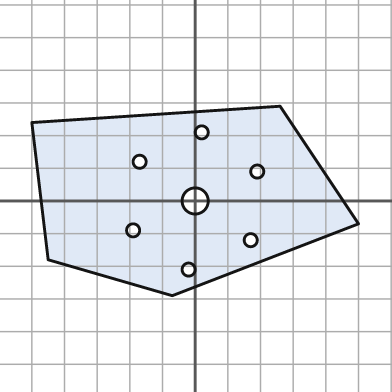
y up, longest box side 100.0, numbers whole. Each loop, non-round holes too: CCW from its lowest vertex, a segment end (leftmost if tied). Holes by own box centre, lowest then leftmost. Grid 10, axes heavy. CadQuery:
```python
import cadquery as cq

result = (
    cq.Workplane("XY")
    .moveTo(-7.0, -29.0)
    .lineTo(50.0, -7.0)
    .lineTo(26.0, 29.0)
    .lineTo(-50.0, 24.0)
    .lineTo(-45.0, -18.0)
    .close()
    .moveTo(-2.0, -21.0)
    .circle(2.0)
    .moveTo(17.0, -12.0)
    .circle(2.0)
    .moveTo(-19.0, -9.0)
    .circle(2.0)
    .moveTo(0.0, 0.0)
    .circle(4.0)
    .moveTo(19.0, 9.0)
    .circle(2.0)
    .moveTo(-17.0, 12.0)
    .circle(2.0)
    .moveTo(2.0, 21.0)
    .circle(2.0)
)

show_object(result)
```